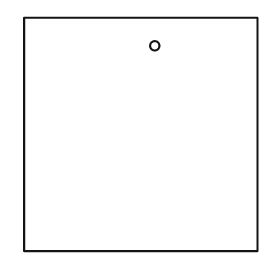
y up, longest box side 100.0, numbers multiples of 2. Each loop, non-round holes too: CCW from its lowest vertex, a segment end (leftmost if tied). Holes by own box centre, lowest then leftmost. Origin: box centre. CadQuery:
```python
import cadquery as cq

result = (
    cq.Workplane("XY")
    .moveTo(-50.0, -50.0)
    .lineTo(50.0, -50.0)
    .lineTo(50.0, 50.0)
    .lineTo(-50.0, 50.0)
    .close()
    .moveTo(6.0, 38.0)
    .circle(2.0)
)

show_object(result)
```